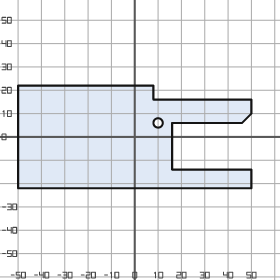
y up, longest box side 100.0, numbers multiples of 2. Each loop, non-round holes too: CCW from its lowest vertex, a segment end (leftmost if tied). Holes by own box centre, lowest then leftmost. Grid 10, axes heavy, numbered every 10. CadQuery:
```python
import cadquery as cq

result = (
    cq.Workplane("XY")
    .moveTo(-50.0, -22.0)
    .lineTo(50.0, -22.0)
    .lineTo(50.0, -14.0)
    .lineTo(16.0, -14.0)
    .lineTo(16.0, 6.0)
    .lineTo(46.0, 6.0)
    .lineTo(50.0, 10.0)
    .lineTo(50.0, 16.0)
    .lineTo(8.0, 16.0)
    .lineTo(8.0, 22.0)
    .lineTo(-50.0, 22.0)
    .close()
    .moveTo(10.0, 6.0)
    .circle(2.0)
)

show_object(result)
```